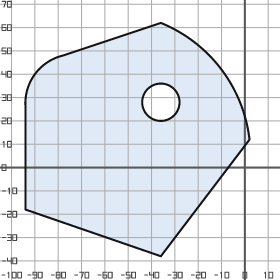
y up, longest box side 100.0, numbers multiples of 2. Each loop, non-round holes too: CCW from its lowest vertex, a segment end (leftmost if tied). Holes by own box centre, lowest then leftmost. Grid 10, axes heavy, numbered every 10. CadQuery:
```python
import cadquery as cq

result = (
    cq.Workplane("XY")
    .moveTo(-36.0, -38.0)
    .lineTo(2.0, 12.0)
    .threePointArc((-10.0, 42.0), (-36.0, 62.0))
    .lineTo(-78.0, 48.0)
    .threePointArc((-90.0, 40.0), (-94.0, 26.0))
    .lineTo(-94.0, -18.0)
    .close()
    .moveTo(-36.0, 28.0)
    .circle(8.0)
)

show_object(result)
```